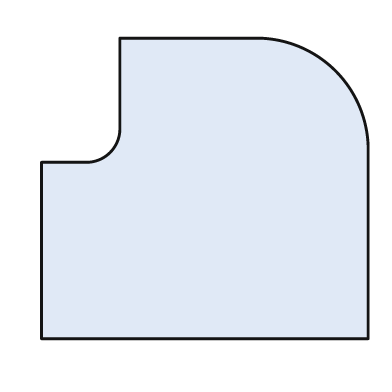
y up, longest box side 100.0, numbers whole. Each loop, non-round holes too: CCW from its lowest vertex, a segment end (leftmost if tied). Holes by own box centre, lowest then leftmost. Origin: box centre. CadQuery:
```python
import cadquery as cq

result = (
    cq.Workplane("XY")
    .moveTo(-50.0, -46.0)
    .lineTo(50.0, -46.0)
    .lineTo(50.0, 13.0)
    .threePointArc((40.0, 36.0), (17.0, 46.0))
    .lineTo(-26.0, 46.0)
    .lineTo(-26.0, 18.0)
    .threePointArc((-29.0, 11.0), (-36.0, 8.0))
    .lineTo(-50.0, 8.0)
    .close()
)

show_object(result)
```